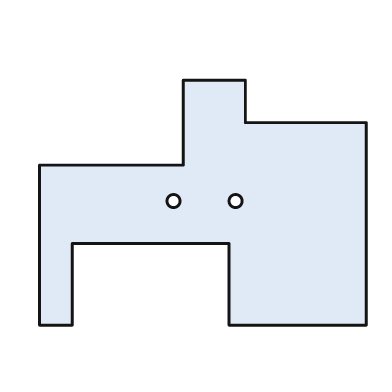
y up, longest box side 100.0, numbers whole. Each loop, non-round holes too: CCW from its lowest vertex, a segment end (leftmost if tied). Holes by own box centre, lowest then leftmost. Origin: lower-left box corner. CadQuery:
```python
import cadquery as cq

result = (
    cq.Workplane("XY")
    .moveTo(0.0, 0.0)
    .lineTo(10.0, 0.0)
    .lineTo(10.0, 25.0)
    .lineTo(58.0, 25.0)
    .lineTo(58.0, 0.0)
    .lineTo(100.0, 0.0)
    .lineTo(100.0, 62.0)
    .lineTo(63.0, 62.0)
    .lineTo(63.0, 75.0)
    .lineTo(44.0, 75.0)
    .lineTo(44.0, 49.0)
    .lineTo(0.0, 49.0)
    .close()
    .moveTo(41.0, 38.0)
    .circle(2.0)
    .moveTo(60.0, 38.0)
    .circle(2.0)
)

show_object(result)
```